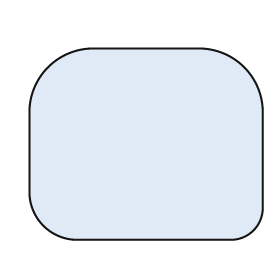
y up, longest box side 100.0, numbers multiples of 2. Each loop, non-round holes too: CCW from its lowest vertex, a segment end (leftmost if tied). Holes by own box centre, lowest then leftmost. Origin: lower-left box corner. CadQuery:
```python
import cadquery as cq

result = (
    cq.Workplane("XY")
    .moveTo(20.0, 0.0)
    .lineTo(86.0, 0.0)
    .threePointArc((96.0, 4.0), (100.0, 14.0))
    .lineTo(100.0, 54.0)
    .threePointArc((92.0, 74.0), (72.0, 82.0))
    .lineTo(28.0, 82.0)
    .threePointArc((8.0, 74.0), (0.0, 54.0))
    .lineTo(0.0, 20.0)
    .threePointArc((6.0, 6.0), (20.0, 0.0))
    .close()
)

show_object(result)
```